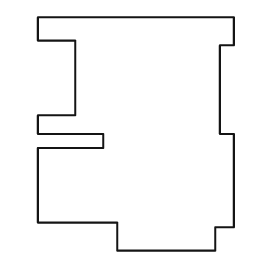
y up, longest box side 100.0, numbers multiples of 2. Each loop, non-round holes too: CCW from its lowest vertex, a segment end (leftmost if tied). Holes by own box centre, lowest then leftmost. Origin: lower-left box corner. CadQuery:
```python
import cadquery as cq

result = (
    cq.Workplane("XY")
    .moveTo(34.0, 0.0)
    .lineTo(76.0, 0.0)
    .lineTo(76.0, 10.0)
    .lineTo(84.0, 10.0)
    .lineTo(84.0, 50.0)
    .lineTo(78.0, 50.0)
    .lineTo(78.0, 88.0)
    .lineTo(84.0, 88.0)
    .lineTo(84.0, 100.0)
    .lineTo(0.0, 100.0)
    .lineTo(0.0, 90.0)
    .lineTo(16.0, 90.0)
    .lineTo(16.0, 58.0)
    .lineTo(0.0, 58.0)
    .lineTo(0.0, 50.0)
    .lineTo(28.0, 50.0)
    .lineTo(28.0, 44.0)
    .lineTo(0.0, 44.0)
    .lineTo(0.0, 12.0)
    .lineTo(34.0, 12.0)
    .close()
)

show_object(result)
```